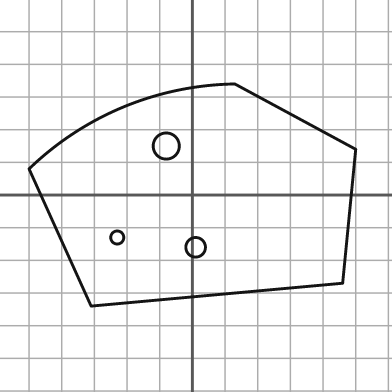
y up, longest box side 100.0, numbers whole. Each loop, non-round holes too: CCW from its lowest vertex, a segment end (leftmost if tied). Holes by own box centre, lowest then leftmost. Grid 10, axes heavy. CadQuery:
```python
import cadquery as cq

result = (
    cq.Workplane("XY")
    .moveTo(-31.0, -34.0)
    .lineTo(46.0, -27.0)
    .lineTo(50.0, 14.0)
    .lineTo(13.0, 34.0)
    .threePointArc((-21.0, 27.0), (-50.0, 8.0))
    .close()
    .moveTo(1.0, -16.0)
    .circle(3.0)
    .moveTo(-23.0, -13.0)
    .circle(2.0)
    .moveTo(-8.0, 15.0)
    .circle(4.0)
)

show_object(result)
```